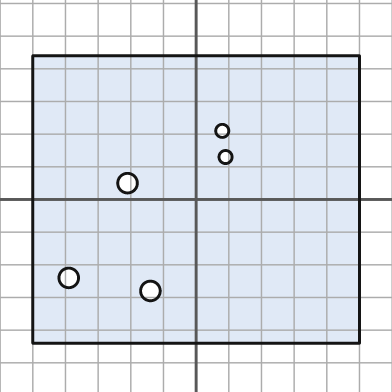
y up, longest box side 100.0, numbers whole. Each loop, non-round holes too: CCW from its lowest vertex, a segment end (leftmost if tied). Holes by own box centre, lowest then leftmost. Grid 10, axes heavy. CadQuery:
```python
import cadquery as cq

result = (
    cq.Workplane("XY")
    .moveTo(-50.0, -44.0)
    .lineTo(50.0, -44.0)
    .lineTo(50.0, 44.0)
    .lineTo(-50.0, 44.0)
    .close()
    .moveTo(-14.0, -28.0)
    .circle(3.0)
    .moveTo(-39.0, -24.0)
    .circle(3.0)
    .moveTo(-21.0, 5.0)
    .circle(3.0)
    .moveTo(9.0, 13.0)
    .circle(2.0)
    .moveTo(8.0, 21.0)
    .circle(2.0)
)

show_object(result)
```